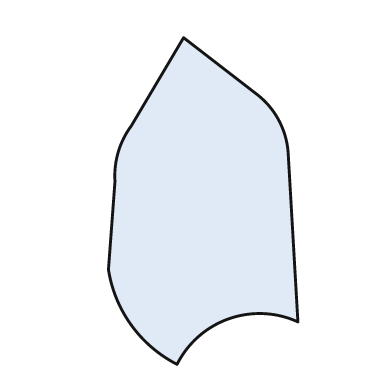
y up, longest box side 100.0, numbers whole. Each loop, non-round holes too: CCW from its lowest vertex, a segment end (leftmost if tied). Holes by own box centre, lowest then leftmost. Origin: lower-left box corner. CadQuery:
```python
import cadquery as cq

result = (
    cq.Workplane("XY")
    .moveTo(21.0, 0.0)
    .threePointArc((37.0, 14.0), (58.0, 13.0))
    .lineTo(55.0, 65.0)
    .threePointArc((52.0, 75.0), (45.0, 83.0))
    .lineTo(23.0, 100.0)
    .lineTo(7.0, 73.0)
    .threePointArc((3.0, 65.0), (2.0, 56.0))
    .lineTo(0.0, 29.0)
    .threePointArc((7.0, 12.0), (21.0, 0.0))
    .close()
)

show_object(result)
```